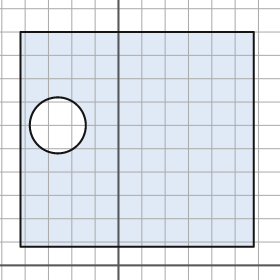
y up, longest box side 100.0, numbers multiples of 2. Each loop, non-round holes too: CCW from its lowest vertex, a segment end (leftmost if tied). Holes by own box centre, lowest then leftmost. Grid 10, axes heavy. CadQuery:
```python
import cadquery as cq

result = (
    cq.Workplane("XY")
    .moveTo(-42.0, 8.0)
    .lineTo(58.0, 8.0)
    .lineTo(58.0, 100.0)
    .lineTo(-42.0, 100.0)
    .close()
    .moveTo(-26.0, 60.0)
    .circle(12.0)
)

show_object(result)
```